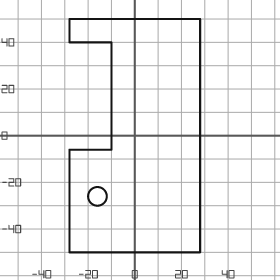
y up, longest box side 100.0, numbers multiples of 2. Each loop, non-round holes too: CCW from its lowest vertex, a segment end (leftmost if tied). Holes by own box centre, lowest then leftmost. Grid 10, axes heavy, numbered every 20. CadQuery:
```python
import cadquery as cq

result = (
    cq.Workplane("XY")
    .moveTo(-28.0, -50.0)
    .lineTo(28.0, -50.0)
    .lineTo(28.0, 50.0)
    .lineTo(-28.0, 50.0)
    .lineTo(-28.0, 40.0)
    .lineTo(-10.0, 40.0)
    .lineTo(-10.0, -6.0)
    .lineTo(-28.0, -6.0)
    .close()
    .moveTo(-16.0, -26.0)
    .circle(4.0)
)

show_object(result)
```